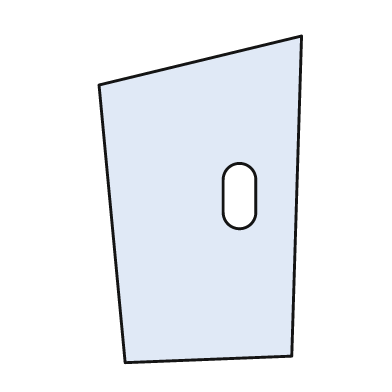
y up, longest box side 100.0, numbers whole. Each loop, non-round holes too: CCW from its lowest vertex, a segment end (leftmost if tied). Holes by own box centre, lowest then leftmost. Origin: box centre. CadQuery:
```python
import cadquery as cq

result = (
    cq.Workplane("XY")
    .moveTo(-23.0, -50.0)
    .lineTo(28.0, -48.0)
    .lineTo(31.0, 50.0)
    .lineTo(-31.0, 35.0)
    .close()
    .moveTo(7.0, -4.0)
    .threePointArc((12.0, -9.0), (17.0, -4.0))
    .lineTo(17.0, 6.0)
    .threePointArc((12.0, 11.0), (7.0, 6.0))
    .close()
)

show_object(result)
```